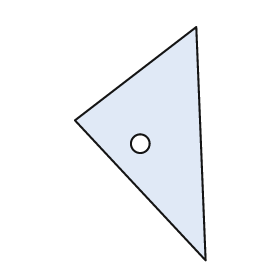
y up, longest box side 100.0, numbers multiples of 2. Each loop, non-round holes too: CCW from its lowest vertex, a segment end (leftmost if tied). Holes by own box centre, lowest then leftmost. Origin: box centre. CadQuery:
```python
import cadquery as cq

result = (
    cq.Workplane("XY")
    .moveTo(28.0, -50.0)
    .lineTo(24.0, 50.0)
    .lineTo(-28.0, 10.0)
    .close()
    .moveTo(0.0, 0.0)
    .circle(4.0)
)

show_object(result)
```